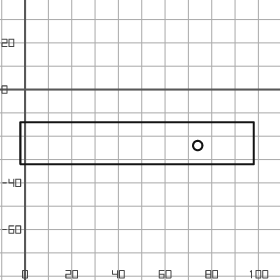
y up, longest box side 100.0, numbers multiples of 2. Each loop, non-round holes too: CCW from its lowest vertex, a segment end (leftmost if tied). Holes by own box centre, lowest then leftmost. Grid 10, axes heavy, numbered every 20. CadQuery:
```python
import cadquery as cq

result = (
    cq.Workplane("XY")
    .moveTo(-2.0, -32.0)
    .lineTo(98.0, -32.0)
    .lineTo(98.0, -14.0)
    .lineTo(-2.0, -14.0)
    .close()
    .moveTo(74.0, -24.0)
    .circle(2.0)
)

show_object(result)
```